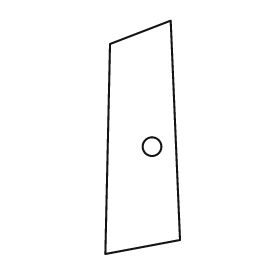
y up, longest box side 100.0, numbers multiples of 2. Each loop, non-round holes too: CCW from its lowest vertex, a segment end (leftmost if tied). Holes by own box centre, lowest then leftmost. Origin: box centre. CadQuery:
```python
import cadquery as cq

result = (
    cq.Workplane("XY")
    .moveTo(-16.0, -50.0)
    .lineTo(16.0, -44.0)
    .lineTo(12.0, 50.0)
    .lineTo(-14.0, 40.0)
    .close()
    .moveTo(4.0, -4.0)
    .circle(4.0)
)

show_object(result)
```